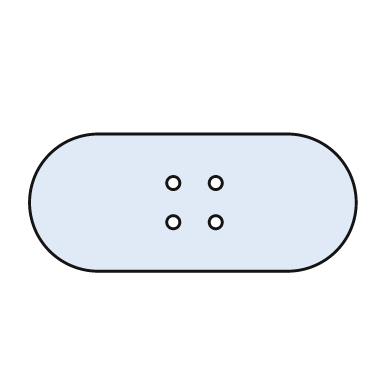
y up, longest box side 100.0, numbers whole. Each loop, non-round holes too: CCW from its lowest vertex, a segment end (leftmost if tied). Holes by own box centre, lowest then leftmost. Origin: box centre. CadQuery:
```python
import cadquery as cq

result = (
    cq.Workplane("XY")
    .moveTo(-29.0, -21.0)
    .lineTo(29.0, -21.0)
    .threePointArc((50.0, 0.0), (29.0, 21.0))
    .lineTo(-29.0, 21.0)
    .threePointArc((-50.0, 0.0), (-29.0, -21.0))
    .close()
    .moveTo(-6.0, -6.0)
    .circle(2.0)
    .moveTo(7.0, -6.0)
    .circle(2.0)
    .moveTo(-6.0, 6.0)
    .circle(2.0)
    .moveTo(7.0, 6.0)
    .circle(2.0)
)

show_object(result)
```